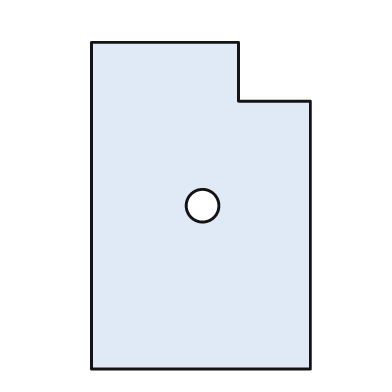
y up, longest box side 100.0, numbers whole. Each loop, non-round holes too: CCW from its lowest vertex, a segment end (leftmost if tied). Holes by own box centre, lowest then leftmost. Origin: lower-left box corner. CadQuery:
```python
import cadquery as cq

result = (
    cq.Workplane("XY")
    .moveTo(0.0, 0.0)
    .lineTo(67.0, 0.0)
    .lineTo(67.0, 82.0)
    .lineTo(45.0, 82.0)
    .lineTo(45.0, 100.0)
    .lineTo(0.0, 100.0)
    .close()
    .moveTo(34.0, 50.0)
    .circle(5.0)
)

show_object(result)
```